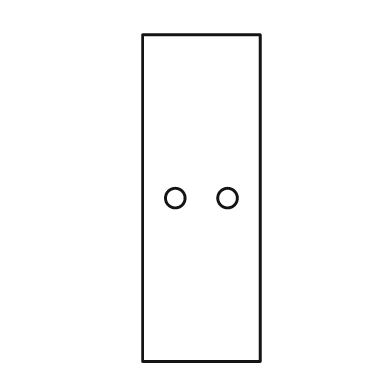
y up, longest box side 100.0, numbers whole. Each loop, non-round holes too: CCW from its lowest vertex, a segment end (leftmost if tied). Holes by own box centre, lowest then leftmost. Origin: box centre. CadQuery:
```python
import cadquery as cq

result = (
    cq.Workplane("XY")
    .moveTo(-18.0, -50.0)
    .lineTo(18.0, -50.0)
    .lineTo(18.0, 50.0)
    .lineTo(-18.0, 50.0)
    .close()
    .moveTo(-8.0, 0.0)
    .circle(3.0)
    .moveTo(8.0, 0.0)
    .circle(3.0)
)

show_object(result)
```